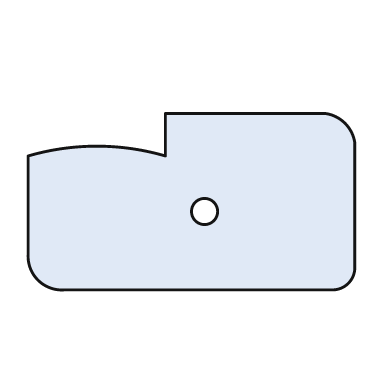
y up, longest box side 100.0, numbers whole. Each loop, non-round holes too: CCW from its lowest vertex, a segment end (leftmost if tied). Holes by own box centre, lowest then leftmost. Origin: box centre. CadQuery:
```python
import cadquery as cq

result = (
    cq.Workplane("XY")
    .moveTo(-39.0, -27.0)
    .lineTo(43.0, -27.0)
    .threePointArc((48.0, -25.0), (50.0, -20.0))
    .lineTo(50.0, 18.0)
    .threePointArc((47.0, 24.0), (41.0, 27.0))
    .lineTo(-8.0, 27.0)
    .lineTo(-8.0, 14.0)
    .threePointArc((-29.0, 17.0), (-50.0, 14.0))
    .lineTo(-50.0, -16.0)
    .threePointArc((-47.0, -24.0), (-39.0, -27.0))
    .close()
    .moveTo(4.0, -3.0)
    .circle(4.0)
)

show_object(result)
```